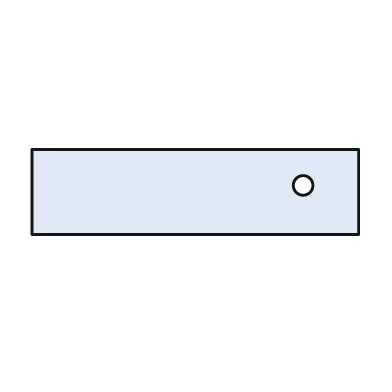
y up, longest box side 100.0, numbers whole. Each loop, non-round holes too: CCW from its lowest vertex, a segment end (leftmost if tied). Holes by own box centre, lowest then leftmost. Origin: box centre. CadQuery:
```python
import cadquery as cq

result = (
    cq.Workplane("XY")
    .moveTo(-50.0, -13.0)
    .lineTo(50.0, -13.0)
    .lineTo(50.0, 13.0)
    .lineTo(-50.0, 13.0)
    .close()
    .moveTo(33.0, 2.0)
    .circle(3.0)
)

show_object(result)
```